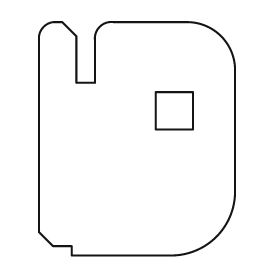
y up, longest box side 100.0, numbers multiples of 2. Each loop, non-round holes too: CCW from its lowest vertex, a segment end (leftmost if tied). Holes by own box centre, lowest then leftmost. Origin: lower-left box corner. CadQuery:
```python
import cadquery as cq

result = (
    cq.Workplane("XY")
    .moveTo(14.0, 0.0)
    .lineTo(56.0, 0.0)
    .threePointArc((76.0, 8.0), (84.0, 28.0))
    .lineTo(84.0, 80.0)
    .threePointArc((78.0, 94.0), (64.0, 100.0))
    .lineTo(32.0, 100.0)
    .threePointArc((26.0, 98.0), (24.0, 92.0))
    .lineTo(24.0, 74.0)
    .lineTo(16.0, 74.0)
    .lineTo(16.0, 94.0)
    .lineTo(10.0, 100.0)
    .lineTo(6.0, 100.0)
    .threePointArc((2.0, 98.0), (0.0, 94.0))
    .lineTo(0.0, 10.0)
    .lineTo(6.0, 4.0)
    .lineTo(14.0, 4.0)
    .close()
    .moveTo(50.0, 54.0)
    .lineTo(66.0, 54.0)
    .lineTo(66.0, 70.0)
    .lineTo(50.0, 70.0)
    .close()
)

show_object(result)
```